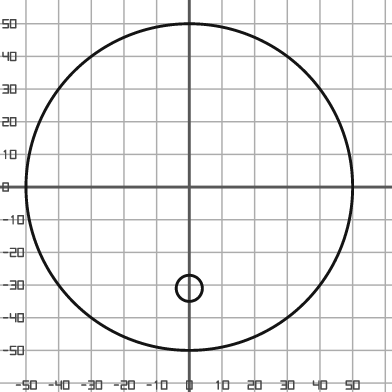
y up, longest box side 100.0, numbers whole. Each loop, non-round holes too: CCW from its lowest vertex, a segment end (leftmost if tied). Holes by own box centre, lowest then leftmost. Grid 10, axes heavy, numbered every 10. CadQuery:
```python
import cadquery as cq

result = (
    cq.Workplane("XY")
    .moveTo(0.0, 0.0)
    .circle(50.0)
    .moveTo(0.0, -31.0)
    .circle(4.0)
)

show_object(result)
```